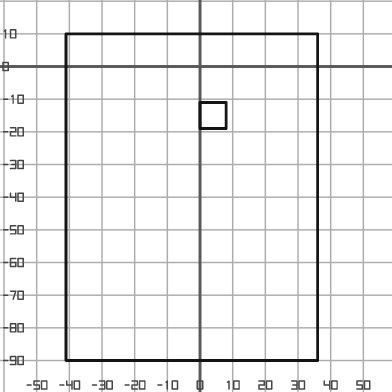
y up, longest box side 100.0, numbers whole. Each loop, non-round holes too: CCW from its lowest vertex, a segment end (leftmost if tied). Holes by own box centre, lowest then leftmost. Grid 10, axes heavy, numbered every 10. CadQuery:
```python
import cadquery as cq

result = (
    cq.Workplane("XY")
    .moveTo(-41.0, -90.0)
    .lineTo(36.0, -90.0)
    .lineTo(36.0, 10.0)
    .lineTo(-41.0, 10.0)
    .close()
    .moveTo(0.0, -19.0)
    .lineTo(8.0, -19.0)
    .lineTo(8.0, -11.0)
    .lineTo(0.0, -11.0)
    .close()
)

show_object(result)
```